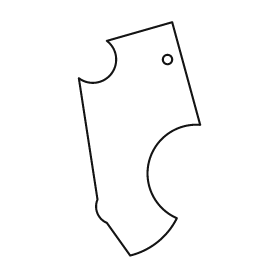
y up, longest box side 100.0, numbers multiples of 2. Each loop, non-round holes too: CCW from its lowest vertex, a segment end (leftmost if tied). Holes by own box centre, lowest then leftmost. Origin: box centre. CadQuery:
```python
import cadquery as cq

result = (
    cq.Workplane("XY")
    .moveTo(-4.0, -50.0)
    .threePointArc((8.0, -44.0), (16.0, -34.0))
    .threePointArc((4.0, -10.0), (26.0, 6.0))
    .lineTo(14.0, 50.0)
    .lineTo(-14.0, 42.0)
    .threePointArc((-12.0, 28.0), (-26.0, 26.0))
    .lineTo(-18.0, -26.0)
    .threePointArc((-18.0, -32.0), (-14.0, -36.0))
    .close()
    .moveTo(12.0, 34.0)
    .circle(2.0)
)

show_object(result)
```